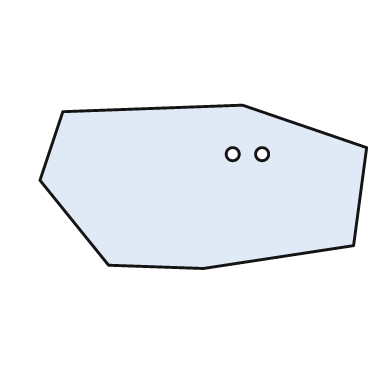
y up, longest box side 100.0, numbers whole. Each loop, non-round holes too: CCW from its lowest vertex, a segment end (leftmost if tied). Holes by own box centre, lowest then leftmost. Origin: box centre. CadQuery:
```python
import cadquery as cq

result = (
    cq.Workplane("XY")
    .moveTo(0.0, -25.0)
    .lineTo(46.0, -18.0)
    .lineTo(50.0, 12.0)
    .lineTo(12.0, 25.0)
    .lineTo(-43.0, 23.0)
    .lineTo(-50.0, 2.0)
    .lineTo(-29.0, -24.0)
    .close()
    .moveTo(9.0, 10.0)
    .circle(2.0)
    .moveTo(18.0, 10.0)
    .circle(2.0)
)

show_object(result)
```